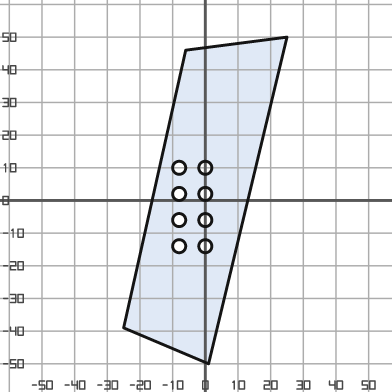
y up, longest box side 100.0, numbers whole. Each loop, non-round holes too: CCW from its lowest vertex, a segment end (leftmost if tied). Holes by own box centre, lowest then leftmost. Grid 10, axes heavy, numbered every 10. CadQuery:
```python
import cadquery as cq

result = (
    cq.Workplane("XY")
    .moveTo(1.0, -50.0)
    .lineTo(25.0, 50.0)
    .lineTo(-6.0, 46.0)
    .lineTo(-25.0, -39.0)
    .close()
    .moveTo(-8.0, -14.0)
    .circle(2.0)
    .moveTo(0.0, -14.0)
    .circle(2.0)
    .moveTo(-8.0, -6.0)
    .circle(2.0)
    .moveTo(0.0, -6.0)
    .circle(2.0)
    .moveTo(-8.0, 2.0)
    .circle(2.0)
    .moveTo(0.0, 2.0)
    .circle(2.0)
    .moveTo(-8.0, 10.0)
    .circle(2.0)
    .moveTo(0.0, 10.0)
    .circle(2.0)
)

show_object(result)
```